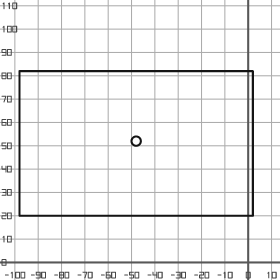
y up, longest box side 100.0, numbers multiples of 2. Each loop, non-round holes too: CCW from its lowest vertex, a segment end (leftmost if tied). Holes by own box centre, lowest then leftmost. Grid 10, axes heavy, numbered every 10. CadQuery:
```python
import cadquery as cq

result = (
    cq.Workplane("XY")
    .moveTo(-98.0, 20.0)
    .lineTo(2.0, 20.0)
    .lineTo(2.0, 82.0)
    .lineTo(-98.0, 82.0)
    .close()
    .moveTo(-48.0, 52.0)
    .circle(2.0)
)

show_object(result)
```